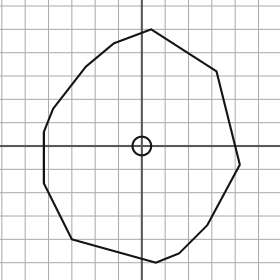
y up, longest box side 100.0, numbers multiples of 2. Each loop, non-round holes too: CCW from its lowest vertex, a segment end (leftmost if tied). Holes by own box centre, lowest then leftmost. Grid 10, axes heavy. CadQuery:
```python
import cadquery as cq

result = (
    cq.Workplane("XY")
    .moveTo(6.0, -50.0)
    .lineTo(16.0, -46.0)
    .lineTo(28.0, -34.0)
    .lineTo(42.0, -8.0)
    .lineTo(32.0, 32.0)
    .lineTo(4.0, 50.0)
    .lineTo(-12.0, 44.0)
    .lineTo(-24.0, 34.0)
    .lineTo(-38.0, 16.0)
    .lineTo(-42.0, 6.0)
    .lineTo(-42.0, -16.0)
    .lineTo(-30.0, -40.0)
    .close()
    .moveTo(0.0, 0.0)
    .circle(4.0)
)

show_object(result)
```